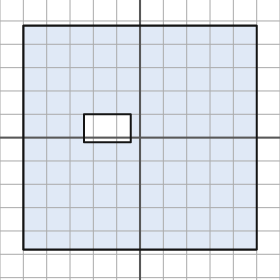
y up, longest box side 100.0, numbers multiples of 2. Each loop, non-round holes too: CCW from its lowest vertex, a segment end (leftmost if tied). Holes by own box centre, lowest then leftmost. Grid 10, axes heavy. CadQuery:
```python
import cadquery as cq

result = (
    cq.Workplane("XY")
    .moveTo(-50.0, -48.0)
    .lineTo(50.0, -48.0)
    .lineTo(50.0, 48.0)
    .lineTo(-50.0, 48.0)
    .close()
    .moveTo(-24.0, -2.0)
    .lineTo(-4.0, -2.0)
    .lineTo(-4.0, 10.0)
    .lineTo(-24.0, 10.0)
    .close()
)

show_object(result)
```